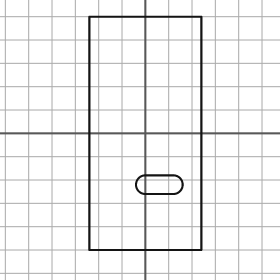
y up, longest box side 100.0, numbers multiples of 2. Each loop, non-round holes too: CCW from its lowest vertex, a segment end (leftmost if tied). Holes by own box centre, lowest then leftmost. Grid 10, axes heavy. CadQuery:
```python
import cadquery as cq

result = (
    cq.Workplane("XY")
    .moveTo(-24.0, -50.0)
    .lineTo(24.0, -50.0)
    .lineTo(24.0, 50.0)
    .lineTo(-24.0, 50.0)
    .close()
    .moveTo(0.0, -26.0)
    .lineTo(12.0, -26.0)
    .threePointArc((16.0, -22.0), (12.0, -18.0))
    .lineTo(0.0, -18.0)
    .threePointArc((-4.0, -22.0), (0.0, -26.0))
    .close()
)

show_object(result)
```